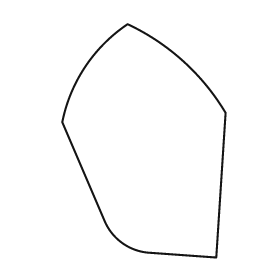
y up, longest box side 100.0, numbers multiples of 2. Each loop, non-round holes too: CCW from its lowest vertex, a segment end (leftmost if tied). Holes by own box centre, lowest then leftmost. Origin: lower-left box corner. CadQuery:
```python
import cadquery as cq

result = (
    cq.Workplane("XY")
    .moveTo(66.0, 0.0)
    .lineTo(70.0, 62.0)
    .threePointArc((52.0, 84.0), (28.0, 100.0))
    .threePointArc((10.0, 82.0), (0.0, 58.0))
    .lineTo(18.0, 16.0)
    .threePointArc((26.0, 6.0), (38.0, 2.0))
    .close()
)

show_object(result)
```